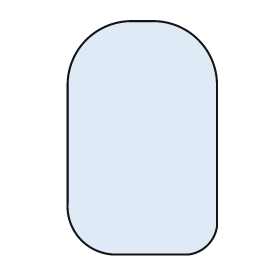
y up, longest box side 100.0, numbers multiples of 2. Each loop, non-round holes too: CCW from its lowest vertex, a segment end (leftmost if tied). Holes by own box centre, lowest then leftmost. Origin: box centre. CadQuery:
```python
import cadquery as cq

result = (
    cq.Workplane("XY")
    .moveTo(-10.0, -50.0)
    .lineTo(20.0, -50.0)
    .threePointArc((28.0, -46.0), (32.0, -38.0))
    .lineTo(32.0, 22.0)
    .threePointArc((24.0, 42.0), (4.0, 50.0))
    .lineTo(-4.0, 50.0)
    .threePointArc((-24.0, 42.0), (-32.0, 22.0))
    .lineTo(-32.0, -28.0)
    .threePointArc((-26.0, -44.0), (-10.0, -50.0))
    .close()
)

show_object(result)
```